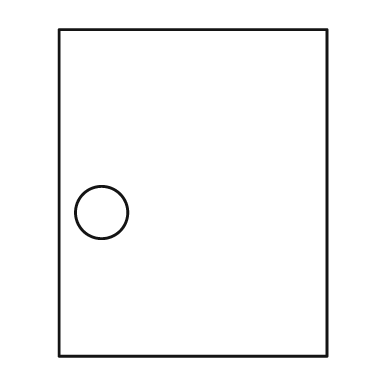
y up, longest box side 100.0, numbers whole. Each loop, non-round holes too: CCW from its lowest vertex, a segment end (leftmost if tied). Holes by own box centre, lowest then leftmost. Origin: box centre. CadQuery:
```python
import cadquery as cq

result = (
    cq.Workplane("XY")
    .moveTo(-41.0, -50.0)
    .lineTo(41.0, -50.0)
    .lineTo(41.0, 50.0)
    .lineTo(-41.0, 50.0)
    .close()
    .moveTo(-28.0, -6.0)
    .circle(8.0)
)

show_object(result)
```